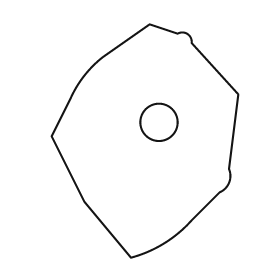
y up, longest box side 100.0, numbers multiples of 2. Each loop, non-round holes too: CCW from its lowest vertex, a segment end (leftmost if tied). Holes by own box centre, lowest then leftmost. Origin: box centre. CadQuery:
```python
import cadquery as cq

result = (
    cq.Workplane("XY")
    .moveTo(-6.0, -50.0)
    .threePointArc((8.0, -44.0), (20.0, -34.0))
    .lineTo(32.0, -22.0)
    .threePointArc((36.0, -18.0), (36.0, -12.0))
    .lineTo(40.0, 20.0)
    .lineTo(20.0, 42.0)
    .threePointArc((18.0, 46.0), (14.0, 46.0))
    .lineTo(2.0, 50.0)
    .lineTo(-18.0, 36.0)
    .threePointArc((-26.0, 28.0), (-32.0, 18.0))
    .lineTo(-40.0, 2.0)
    .lineTo(-26.0, -26.0)
    .close()
    .moveTo(6.0, 8.0)
    .circle(8.0)
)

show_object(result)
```